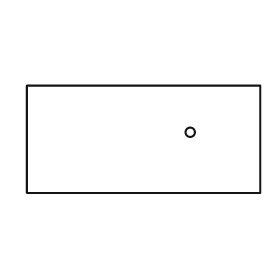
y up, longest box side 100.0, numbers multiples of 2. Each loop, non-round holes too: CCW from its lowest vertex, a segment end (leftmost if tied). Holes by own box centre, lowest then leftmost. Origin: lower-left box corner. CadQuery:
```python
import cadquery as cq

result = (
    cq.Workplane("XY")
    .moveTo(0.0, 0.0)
    .lineTo(100.0, 0.0)
    .lineTo(100.0, 46.0)
    .lineTo(0.0, 46.0)
    .close()
    .moveTo(70.0, 26.0)
    .circle(2.0)
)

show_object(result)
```